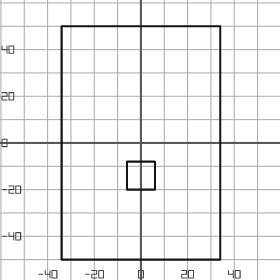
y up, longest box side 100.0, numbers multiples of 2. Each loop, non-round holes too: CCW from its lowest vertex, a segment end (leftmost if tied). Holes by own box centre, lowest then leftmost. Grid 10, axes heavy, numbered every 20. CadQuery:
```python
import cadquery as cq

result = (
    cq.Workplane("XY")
    .moveTo(-34.0, -50.0)
    .lineTo(34.0, -50.0)
    .lineTo(34.0, 50.0)
    .lineTo(-34.0, 50.0)
    .close()
    .moveTo(-6.0, -20.0)
    .lineTo(6.0, -20.0)
    .lineTo(6.0, -8.0)
    .lineTo(-6.0, -8.0)
    .close()
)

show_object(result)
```